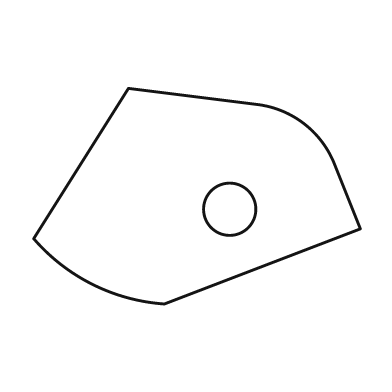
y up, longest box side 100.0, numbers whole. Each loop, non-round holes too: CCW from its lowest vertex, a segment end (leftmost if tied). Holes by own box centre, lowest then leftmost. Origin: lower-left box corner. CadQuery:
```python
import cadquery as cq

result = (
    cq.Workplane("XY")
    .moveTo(40.0, 0.0)
    .lineTo(100.0, 23.0)
    .lineTo(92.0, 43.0)
    .threePointArc((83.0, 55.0), (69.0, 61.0))
    .lineTo(29.0, 66.0)
    .lineTo(0.0, 20.0)
    .threePointArc((18.0, 6.0), (40.0, 0.0))
    .close()
    .moveTo(60.0, 29.0)
    .circle(8.0)
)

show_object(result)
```